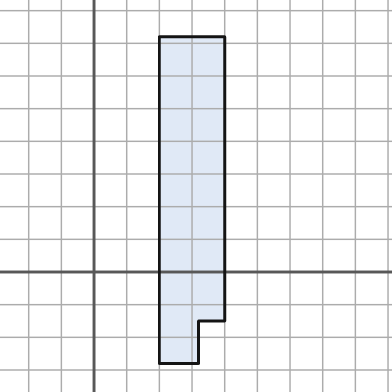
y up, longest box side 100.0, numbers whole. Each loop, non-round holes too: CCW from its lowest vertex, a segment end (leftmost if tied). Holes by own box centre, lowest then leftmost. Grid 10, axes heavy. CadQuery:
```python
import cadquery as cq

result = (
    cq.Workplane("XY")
    .moveTo(20.0, -28.0)
    .lineTo(32.0, -28.0)
    .lineTo(32.0, -15.0)
    .lineTo(40.0, -15.0)
    .lineTo(40.0, 72.0)
    .lineTo(20.0, 72.0)
    .close()
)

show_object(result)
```